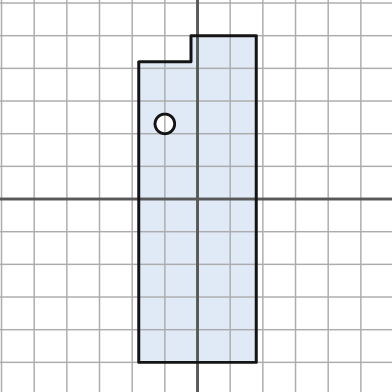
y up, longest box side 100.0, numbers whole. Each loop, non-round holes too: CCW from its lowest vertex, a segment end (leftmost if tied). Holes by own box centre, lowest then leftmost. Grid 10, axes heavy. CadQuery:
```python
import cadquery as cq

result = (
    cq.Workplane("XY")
    .moveTo(-18.0, -50.0)
    .lineTo(18.0, -50.0)
    .lineTo(18.0, 50.0)
    .lineTo(-2.0, 50.0)
    .lineTo(-2.0, 42.0)
    .lineTo(-18.0, 42.0)
    .close()
    .moveTo(-10.0, 23.0)
    .circle(3.0)
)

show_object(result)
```